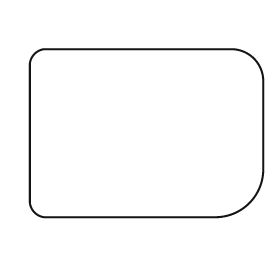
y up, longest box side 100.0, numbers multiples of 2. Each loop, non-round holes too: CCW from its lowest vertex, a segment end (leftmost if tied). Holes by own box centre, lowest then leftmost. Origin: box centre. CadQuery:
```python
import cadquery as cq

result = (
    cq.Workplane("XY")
    .moveTo(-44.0, -36.0)
    .lineTo(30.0, -36.0)
    .threePointArc((44.0, -30.0), (50.0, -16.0))
    .lineTo(50.0, 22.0)
    .threePointArc((46.0, 32.0), (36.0, 36.0))
    .lineTo(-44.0, 36.0)
    .threePointArc((-48.0, 34.0), (-50.0, 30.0))
    .lineTo(-50.0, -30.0)
    .threePointArc((-48.0, -34.0), (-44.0, -36.0))
    .close()
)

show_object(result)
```